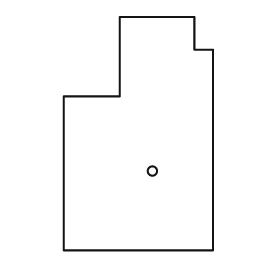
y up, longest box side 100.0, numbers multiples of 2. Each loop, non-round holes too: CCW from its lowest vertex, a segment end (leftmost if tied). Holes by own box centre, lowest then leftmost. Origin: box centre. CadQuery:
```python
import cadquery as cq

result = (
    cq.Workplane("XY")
    .moveTo(-32.0, -50.0)
    .lineTo(32.0, -50.0)
    .lineTo(32.0, 36.0)
    .lineTo(24.0, 36.0)
    .lineTo(24.0, 50.0)
    .lineTo(-8.0, 50.0)
    .lineTo(-8.0, 16.0)
    .lineTo(-32.0, 16.0)
    .close()
    .moveTo(6.0, -16.0)
    .circle(2.0)
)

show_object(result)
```